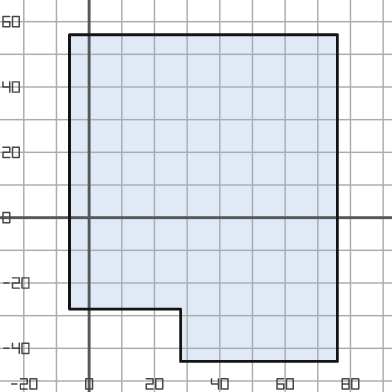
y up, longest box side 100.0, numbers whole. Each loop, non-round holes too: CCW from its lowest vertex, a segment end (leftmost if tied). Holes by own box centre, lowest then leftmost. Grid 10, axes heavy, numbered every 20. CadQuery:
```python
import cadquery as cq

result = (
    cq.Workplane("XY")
    .moveTo(28.0, -44.0)
    .lineTo(76.0, -44.0)
    .lineTo(76.0, 56.0)
    .lineTo(-6.0, 56.0)
    .lineTo(-6.0, -28.0)
    .lineTo(28.0, -28.0)
    .close()
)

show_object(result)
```